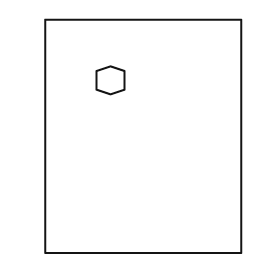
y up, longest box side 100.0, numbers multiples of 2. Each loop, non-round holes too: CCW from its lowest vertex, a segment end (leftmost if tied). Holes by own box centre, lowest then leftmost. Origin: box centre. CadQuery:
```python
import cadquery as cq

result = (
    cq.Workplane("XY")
    .moveTo(-42.0, -50.0)
    .lineTo(42.0, -50.0)
    .lineTo(42.0, 50.0)
    .lineTo(-42.0, 50.0)
    .close()
    .moveTo(-14.0, 18.0)
    .lineTo(-8.0, 20.0)
    .lineTo(-8.0, 28.0)
    .lineTo(-14.0, 30.0)
    .lineTo(-20.0, 28.0)
    .lineTo(-20.0, 20.0)
    .close()
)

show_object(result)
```